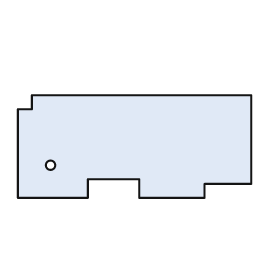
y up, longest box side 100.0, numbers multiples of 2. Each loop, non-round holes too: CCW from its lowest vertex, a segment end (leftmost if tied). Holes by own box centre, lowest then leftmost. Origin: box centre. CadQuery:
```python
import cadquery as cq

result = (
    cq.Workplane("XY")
    .moveTo(-50.0, -22.0)
    .lineTo(-20.0, -22.0)
    .lineTo(-20.0, -14.0)
    .lineTo(2.0, -14.0)
    .lineTo(2.0, -22.0)
    .lineTo(30.0, -22.0)
    .lineTo(30.0, -16.0)
    .lineTo(50.0, -16.0)
    .lineTo(50.0, 22.0)
    .lineTo(-44.0, 22.0)
    .lineTo(-44.0, 16.0)
    .lineTo(-50.0, 16.0)
    .close()
    .moveTo(-36.0, -8.0)
    .circle(2.0)
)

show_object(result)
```